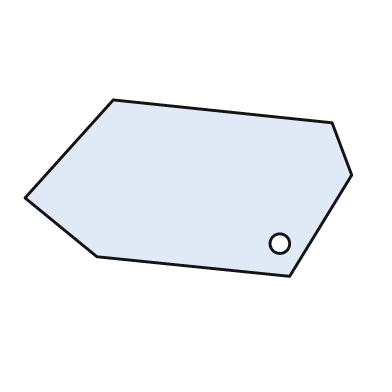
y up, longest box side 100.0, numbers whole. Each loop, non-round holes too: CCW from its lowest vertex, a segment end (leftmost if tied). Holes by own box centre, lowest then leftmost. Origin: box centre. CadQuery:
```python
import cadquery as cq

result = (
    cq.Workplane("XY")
    .moveTo(31.0, -27.0)
    .lineTo(50.0, 4.0)
    .lineTo(44.0, 20.0)
    .lineTo(-23.0, 27.0)
    .lineTo(-50.0, -3.0)
    .lineTo(-28.0, -21.0)
    .close()
    .moveTo(28.0, -17.0)
    .circle(3.0)
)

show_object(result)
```